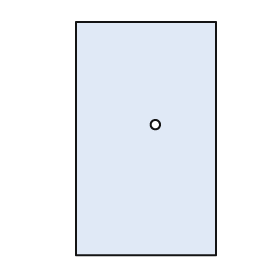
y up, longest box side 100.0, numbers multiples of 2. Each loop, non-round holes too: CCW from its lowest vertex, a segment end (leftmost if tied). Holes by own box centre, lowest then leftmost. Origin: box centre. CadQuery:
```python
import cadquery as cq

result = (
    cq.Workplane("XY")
    .moveTo(-30.0, -50.0)
    .lineTo(30.0, -50.0)
    .lineTo(30.0, 50.0)
    .lineTo(-30.0, 50.0)
    .close()
    .moveTo(4.0, 6.0)
    .circle(2.0)
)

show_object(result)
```